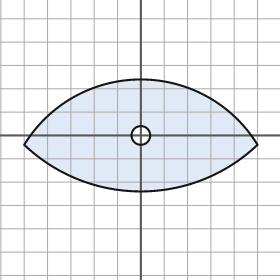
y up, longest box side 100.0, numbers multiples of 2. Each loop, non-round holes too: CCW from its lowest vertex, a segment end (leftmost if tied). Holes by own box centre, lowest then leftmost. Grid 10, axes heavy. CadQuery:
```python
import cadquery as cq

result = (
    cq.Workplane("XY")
    .moveTo(-50.0, -4.0)
    .threePointArc((0.0, -24.0), (50.0, -4.0))
    .threePointArc((0.0, 24.0), (-50.0, -4.0))
    .close()
    .moveTo(0.0, 0.0)
    .circle(4.0)
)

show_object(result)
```